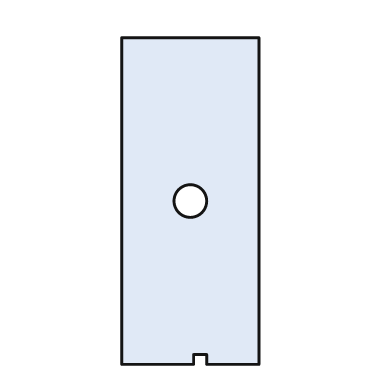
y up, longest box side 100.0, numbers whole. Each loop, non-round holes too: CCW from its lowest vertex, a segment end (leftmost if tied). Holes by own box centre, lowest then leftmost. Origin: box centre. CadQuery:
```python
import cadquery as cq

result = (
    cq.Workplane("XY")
    .moveTo(-21.0, -50.0)
    .lineTo(1.0, -50.0)
    .lineTo(1.0, -47.0)
    .lineTo(5.0, -47.0)
    .lineTo(5.0, -50.0)
    .lineTo(21.0, -50.0)
    .lineTo(21.0, 50.0)
    .lineTo(-21.0, 50.0)
    .close()
    .moveTo(0.0, 0.0)
    .circle(5.0)
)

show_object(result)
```